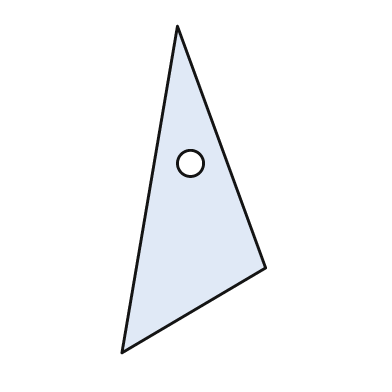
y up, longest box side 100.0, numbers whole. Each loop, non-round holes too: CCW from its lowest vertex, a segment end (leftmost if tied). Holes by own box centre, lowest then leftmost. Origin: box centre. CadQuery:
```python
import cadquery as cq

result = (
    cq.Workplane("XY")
    .moveTo(-22.0, -50.0)
    .lineTo(22.0, -24.0)
    .lineTo(-5.0, 50.0)
    .close()
    .moveTo(-1.0, 8.0)
    .circle(4.0)
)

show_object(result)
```